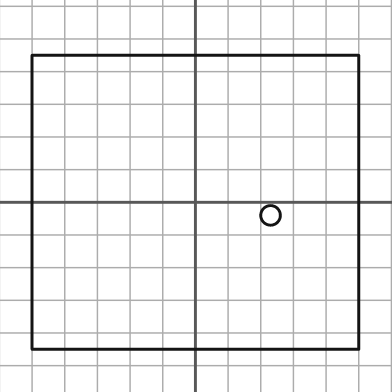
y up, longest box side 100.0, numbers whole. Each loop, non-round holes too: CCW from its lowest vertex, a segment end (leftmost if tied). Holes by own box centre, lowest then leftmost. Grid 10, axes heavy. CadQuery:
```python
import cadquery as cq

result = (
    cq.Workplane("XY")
    .moveTo(-50.0, -45.0)
    .lineTo(50.0, -45.0)
    .lineTo(50.0, 45.0)
    .lineTo(-50.0, 45.0)
    .close()
    .moveTo(23.0, -4.0)
    .circle(3.0)
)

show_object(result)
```